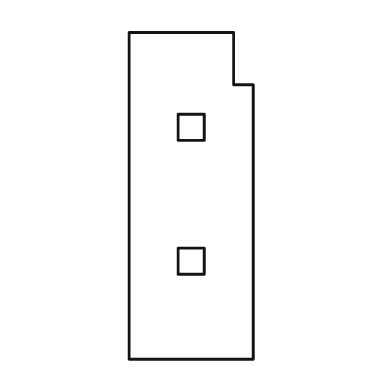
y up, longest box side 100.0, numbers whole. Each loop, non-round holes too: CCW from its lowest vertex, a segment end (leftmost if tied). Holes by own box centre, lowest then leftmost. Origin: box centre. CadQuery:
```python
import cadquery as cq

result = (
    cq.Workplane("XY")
    .moveTo(-19.0, -50.0)
    .lineTo(19.0, -50.0)
    .lineTo(19.0, 34.0)
    .lineTo(13.0, 34.0)
    .lineTo(13.0, 50.0)
    .lineTo(-19.0, 50.0)
    .close()
    .moveTo(-4.0, -24.0)
    .lineTo(4.0, -24.0)
    .lineTo(4.0, -16.0)
    .lineTo(-4.0, -16.0)
    .close()
    .moveTo(-4.0, 17.0)
    .lineTo(4.0, 17.0)
    .lineTo(4.0, 25.0)
    .lineTo(-4.0, 25.0)
    .close()
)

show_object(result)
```